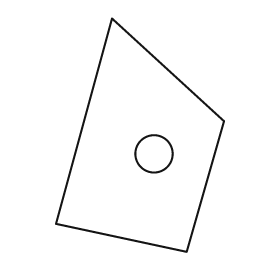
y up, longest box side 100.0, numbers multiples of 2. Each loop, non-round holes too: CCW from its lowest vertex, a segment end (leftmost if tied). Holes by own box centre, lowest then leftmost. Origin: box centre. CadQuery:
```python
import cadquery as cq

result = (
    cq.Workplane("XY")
    .moveTo(20.0, -50.0)
    .lineTo(36.0, 6.0)
    .lineTo(-12.0, 50.0)
    .lineTo(-36.0, -38.0)
    .close()
    .moveTo(6.0, -8.0)
    .circle(8.0)
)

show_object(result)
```